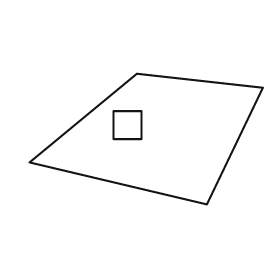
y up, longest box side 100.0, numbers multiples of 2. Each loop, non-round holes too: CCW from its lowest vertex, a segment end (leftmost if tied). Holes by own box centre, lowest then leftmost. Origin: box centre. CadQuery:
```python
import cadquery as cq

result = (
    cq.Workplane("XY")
    .moveTo(26.0, -28.0)
    .lineTo(50.0, 22.0)
    .lineTo(-4.0, 28.0)
    .lineTo(-50.0, -10.0)
    .close()
    .moveTo(-14.0, 0.0)
    .lineTo(-2.0, 0.0)
    .lineTo(-2.0, 12.0)
    .lineTo(-14.0, 12.0)
    .close()
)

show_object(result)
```